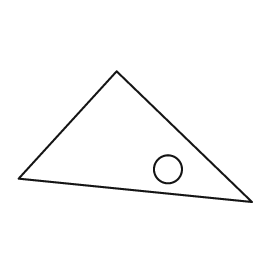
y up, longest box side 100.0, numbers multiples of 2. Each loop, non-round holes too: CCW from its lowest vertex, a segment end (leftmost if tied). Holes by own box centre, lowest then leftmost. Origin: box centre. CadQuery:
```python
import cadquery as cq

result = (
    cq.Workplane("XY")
    .moveTo(50.0, -28.0)
    .lineTo(-8.0, 28.0)
    .lineTo(-50.0, -18.0)
    .close()
    .moveTo(14.0, -14.0)
    .circle(6.0)
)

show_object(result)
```